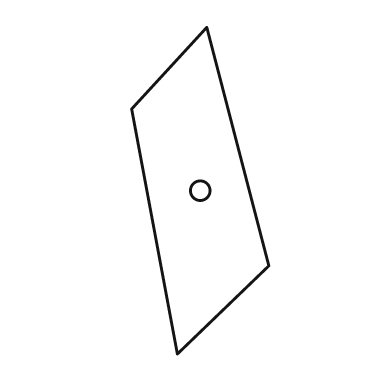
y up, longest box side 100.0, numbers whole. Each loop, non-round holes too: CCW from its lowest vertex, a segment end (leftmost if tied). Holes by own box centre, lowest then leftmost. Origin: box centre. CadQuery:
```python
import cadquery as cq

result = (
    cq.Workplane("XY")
    .moveTo(-7.0, -50.0)
    .lineTo(21.0, -23.0)
    .lineTo(2.0, 50.0)
    .lineTo(-21.0, 25.0)
    .close()
    .moveTo(0.0, 0.0)
    .circle(3.0)
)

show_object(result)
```